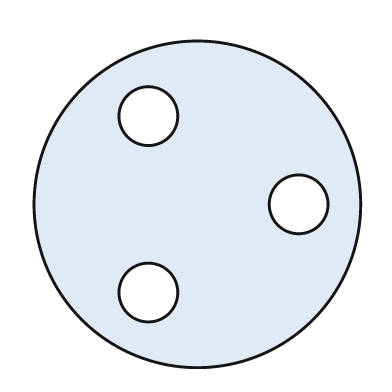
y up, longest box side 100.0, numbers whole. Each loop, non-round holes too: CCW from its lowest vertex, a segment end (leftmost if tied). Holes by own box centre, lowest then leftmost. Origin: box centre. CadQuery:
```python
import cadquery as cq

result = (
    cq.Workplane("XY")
    .moveTo(0.0, 0.0)
    .circle(50.0)
    .moveTo(-15.0, -27.0)
    .circle(9.0)
    .moveTo(31.0, 0.0)
    .circle(9.0)
    .moveTo(-15.0, 27.0)
    .circle(9.0)
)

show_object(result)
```